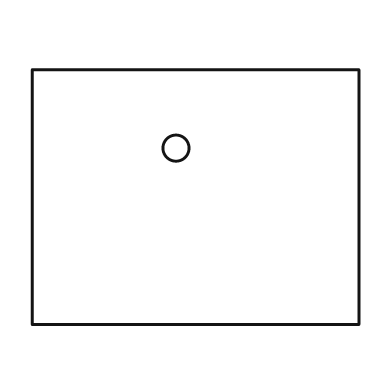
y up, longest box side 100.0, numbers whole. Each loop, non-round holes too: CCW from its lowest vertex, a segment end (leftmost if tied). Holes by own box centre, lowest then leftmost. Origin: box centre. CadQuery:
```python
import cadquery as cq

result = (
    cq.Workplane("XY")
    .moveTo(-50.0, -39.0)
    .lineTo(50.0, -39.0)
    .lineTo(50.0, 39.0)
    .lineTo(-50.0, 39.0)
    .close()
    .moveTo(-6.0, 15.0)
    .circle(4.0)
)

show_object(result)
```